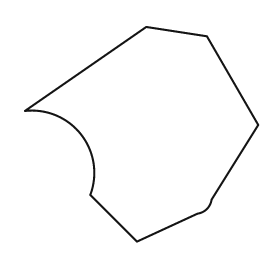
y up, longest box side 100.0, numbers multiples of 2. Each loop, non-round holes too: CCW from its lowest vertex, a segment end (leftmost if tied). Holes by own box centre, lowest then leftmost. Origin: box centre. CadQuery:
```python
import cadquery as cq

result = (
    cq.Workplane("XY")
    .moveTo(-2.0, -46.0)
    .lineTo(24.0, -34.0)
    .threePointArc((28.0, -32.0), (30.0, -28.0))
    .lineTo(50.0, 4.0)
    .lineTo(28.0, 42.0)
    .lineTo(2.0, 46.0)
    .lineTo(-50.0, 10.0)
    .threePointArc((-26.0, 0.0), (-22.0, -26.0))
    .close()
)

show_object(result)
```